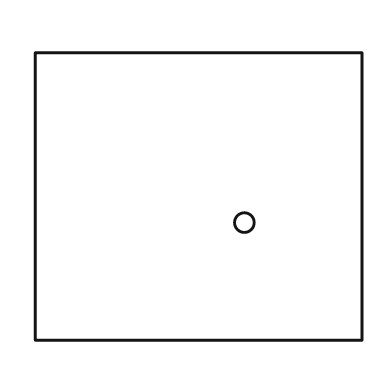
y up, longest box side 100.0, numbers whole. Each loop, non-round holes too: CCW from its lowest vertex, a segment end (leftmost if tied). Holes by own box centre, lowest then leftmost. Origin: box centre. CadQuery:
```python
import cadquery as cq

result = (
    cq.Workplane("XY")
    .moveTo(-50.0, -44.0)
    .lineTo(50.0, -44.0)
    .lineTo(50.0, 44.0)
    .lineTo(-50.0, 44.0)
    .close()
    .moveTo(14.0, -8.0)
    .circle(3.0)
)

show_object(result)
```